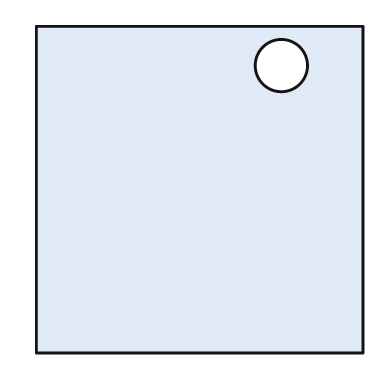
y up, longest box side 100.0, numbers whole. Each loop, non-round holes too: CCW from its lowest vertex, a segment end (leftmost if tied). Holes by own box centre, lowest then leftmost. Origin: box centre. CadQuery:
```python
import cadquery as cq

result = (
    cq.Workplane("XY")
    .moveTo(-50.0, -50.0)
    .lineTo(50.0, -50.0)
    .lineTo(50.0, 50.0)
    .lineTo(-50.0, 50.0)
    .close()
    .moveTo(25.0, 38.0)
    .circle(8.0)
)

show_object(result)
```